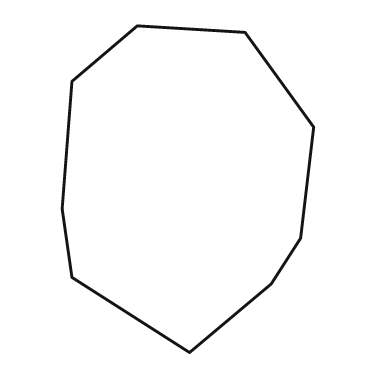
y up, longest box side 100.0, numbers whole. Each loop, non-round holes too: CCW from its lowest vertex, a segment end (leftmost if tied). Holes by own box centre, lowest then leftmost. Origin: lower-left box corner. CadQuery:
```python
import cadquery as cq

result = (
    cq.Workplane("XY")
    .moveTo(39.0, 0.0)
    .lineTo(64.0, 21.0)
    .lineTo(73.0, 35.0)
    .lineTo(77.0, 69.0)
    .lineTo(56.0, 98.0)
    .lineTo(23.0, 100.0)
    .lineTo(3.0, 83.0)
    .lineTo(0.0, 44.0)
    .lineTo(3.0, 23.0)
    .close()
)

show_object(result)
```